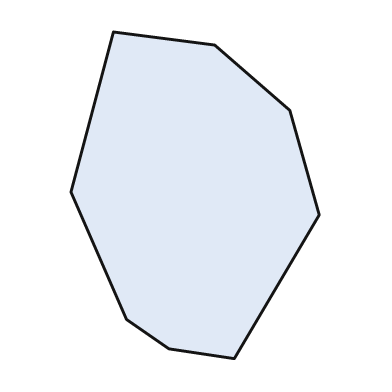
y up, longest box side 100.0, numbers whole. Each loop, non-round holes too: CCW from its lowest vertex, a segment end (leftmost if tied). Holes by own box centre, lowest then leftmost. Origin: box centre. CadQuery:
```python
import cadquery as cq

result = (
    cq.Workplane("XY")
    .moveTo(12.0, -50.0)
    .lineTo(38.0, -6.0)
    .lineTo(29.0, 26.0)
    .lineTo(6.0, 46.0)
    .lineTo(-25.0, 50.0)
    .lineTo(-38.0, 1.0)
    .lineTo(-21.0, -38.0)
    .lineTo(-8.0, -47.0)
    .close()
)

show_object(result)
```